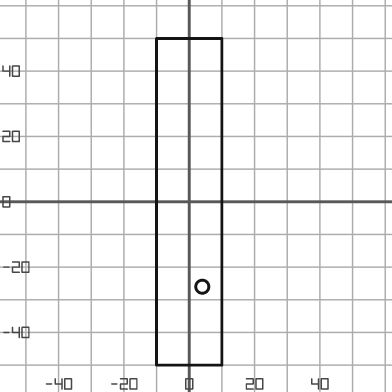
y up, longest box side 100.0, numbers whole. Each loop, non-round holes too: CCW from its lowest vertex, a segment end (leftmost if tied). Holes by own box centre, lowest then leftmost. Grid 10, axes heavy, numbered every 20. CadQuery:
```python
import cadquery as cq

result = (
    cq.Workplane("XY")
    .moveTo(-10.0, -50.0)
    .lineTo(10.0, -50.0)
    .lineTo(10.0, 50.0)
    .lineTo(-10.0, 50.0)
    .close()
    .moveTo(4.0, -26.0)
    .circle(2.0)
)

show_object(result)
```